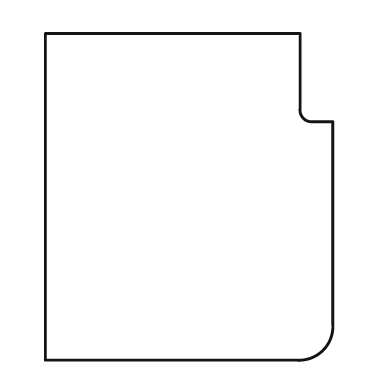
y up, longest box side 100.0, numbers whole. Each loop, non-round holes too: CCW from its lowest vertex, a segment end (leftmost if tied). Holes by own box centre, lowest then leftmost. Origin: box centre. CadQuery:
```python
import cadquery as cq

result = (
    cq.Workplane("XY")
    .moveTo(-44.0, -50.0)
    .lineTo(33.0, -50.0)
    .threePointArc((41.0, -47.0), (44.0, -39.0))
    .lineTo(44.0, 23.0)
    .lineTo(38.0, 23.0)
    .threePointArc((35.0, 24.0), (34.0, 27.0))
    .lineTo(34.0, 50.0)
    .lineTo(-44.0, 50.0)
    .close()
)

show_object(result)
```